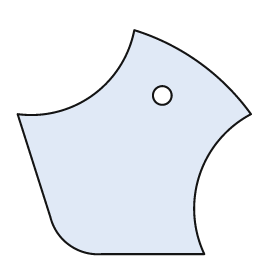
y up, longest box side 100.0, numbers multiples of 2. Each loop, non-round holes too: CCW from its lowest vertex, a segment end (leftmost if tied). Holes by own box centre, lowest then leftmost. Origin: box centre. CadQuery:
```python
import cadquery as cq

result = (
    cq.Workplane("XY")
    .moveTo(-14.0, -48.0)
    .lineTo(30.0, -48.0)
    .threePointArc((28.0, -14.0), (50.0, 12.0))
    .threePointArc((28.0, 34.0), (0.0, 48.0))
    .threePointArc((-18.0, 20.0), (-50.0, 12.0))
    .lineTo(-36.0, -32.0)
    .threePointArc((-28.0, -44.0), (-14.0, -48.0))
    .close()
    .moveTo(12.0, 20.0)
    .circle(4.0)
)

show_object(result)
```